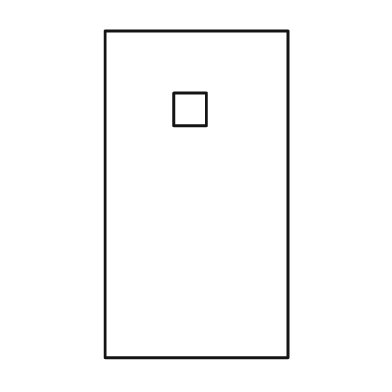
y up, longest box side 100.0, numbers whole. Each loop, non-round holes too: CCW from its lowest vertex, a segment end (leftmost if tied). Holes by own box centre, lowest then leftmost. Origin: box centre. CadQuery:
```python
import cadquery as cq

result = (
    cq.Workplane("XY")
    .moveTo(-28.0, -50.0)
    .lineTo(28.0, -50.0)
    .lineTo(28.0, 50.0)
    .lineTo(-28.0, 50.0)
    .close()
    .moveTo(-7.0, 21.0)
    .lineTo(3.0, 21.0)
    .lineTo(3.0, 31.0)
    .lineTo(-7.0, 31.0)
    .close()
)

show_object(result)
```